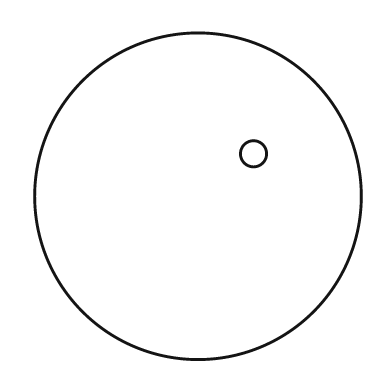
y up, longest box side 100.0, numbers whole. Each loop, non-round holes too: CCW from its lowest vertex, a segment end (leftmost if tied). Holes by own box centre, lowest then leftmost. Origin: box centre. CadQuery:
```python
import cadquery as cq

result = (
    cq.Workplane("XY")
    .moveTo(0.0, 0.0)
    .circle(50.0)
    .moveTo(17.0, 13.0)
    .circle(4.0)
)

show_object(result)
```